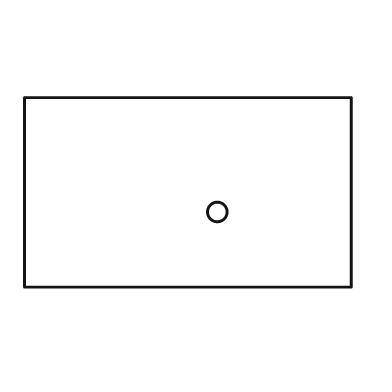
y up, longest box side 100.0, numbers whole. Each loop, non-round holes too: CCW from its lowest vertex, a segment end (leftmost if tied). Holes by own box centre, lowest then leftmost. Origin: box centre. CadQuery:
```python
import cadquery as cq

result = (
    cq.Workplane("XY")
    .moveTo(-50.0, -29.0)
    .lineTo(50.0, -29.0)
    .lineTo(50.0, 29.0)
    .lineTo(-50.0, 29.0)
    .close()
    .moveTo(9.0, -6.0)
    .circle(3.0)
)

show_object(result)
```